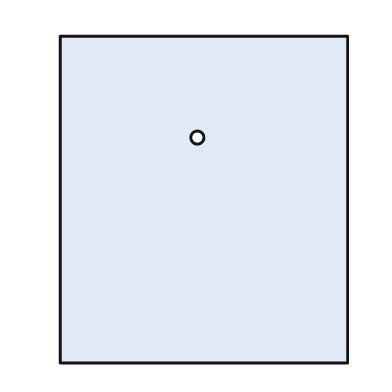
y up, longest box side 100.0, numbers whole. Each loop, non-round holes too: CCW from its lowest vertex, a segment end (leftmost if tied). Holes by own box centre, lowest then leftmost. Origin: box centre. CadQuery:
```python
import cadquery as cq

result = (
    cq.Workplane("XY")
    .moveTo(-44.0, -50.0)
    .lineTo(44.0, -50.0)
    .lineTo(44.0, 50.0)
    .lineTo(-44.0, 50.0)
    .close()
    .moveTo(-2.0, 19.0)
    .circle(2.0)
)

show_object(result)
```